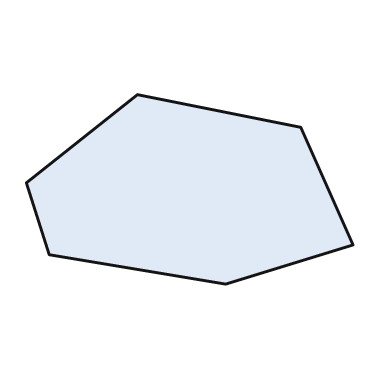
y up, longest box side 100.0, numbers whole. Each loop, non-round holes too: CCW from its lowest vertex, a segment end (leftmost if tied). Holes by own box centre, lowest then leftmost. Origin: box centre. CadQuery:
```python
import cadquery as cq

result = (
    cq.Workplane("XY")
    .moveTo(11.0, -29.0)
    .lineTo(50.0, -17.0)
    .lineTo(34.0, 19.0)
    .lineTo(-16.0, 29.0)
    .lineTo(-50.0, 2.0)
    .lineTo(-43.0, -20.0)
    .close()
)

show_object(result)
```